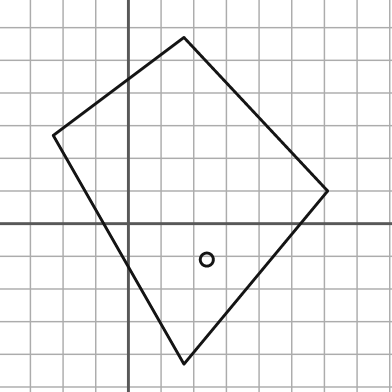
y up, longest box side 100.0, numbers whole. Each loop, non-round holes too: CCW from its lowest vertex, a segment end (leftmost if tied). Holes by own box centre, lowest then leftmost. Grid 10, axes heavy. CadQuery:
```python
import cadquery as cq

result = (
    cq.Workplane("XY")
    .moveTo(17.0, -43.0)
    .lineTo(61.0, 10.0)
    .lineTo(17.0, 57.0)
    .lineTo(-23.0, 27.0)
    .close()
    .moveTo(24.0, -11.0)
    .circle(2.0)
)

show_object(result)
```